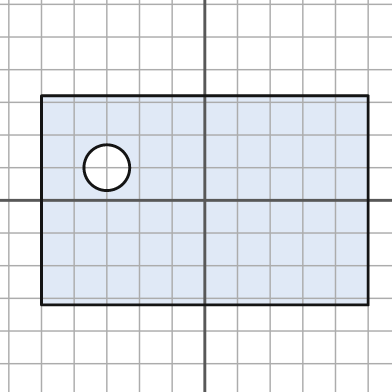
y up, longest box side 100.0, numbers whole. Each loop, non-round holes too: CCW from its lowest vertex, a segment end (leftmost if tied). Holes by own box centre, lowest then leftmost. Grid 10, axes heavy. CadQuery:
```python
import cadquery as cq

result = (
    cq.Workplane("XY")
    .moveTo(-50.0, -32.0)
    .lineTo(50.0, -32.0)
    .lineTo(50.0, 32.0)
    .lineTo(-50.0, 32.0)
    .close()
    .moveTo(-30.0, 10.0)
    .circle(7.0)
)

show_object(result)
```